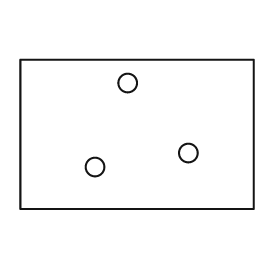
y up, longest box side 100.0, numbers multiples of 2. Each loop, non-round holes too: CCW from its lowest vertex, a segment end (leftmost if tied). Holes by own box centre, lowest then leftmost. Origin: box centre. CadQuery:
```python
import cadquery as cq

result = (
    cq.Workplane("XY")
    .moveTo(-50.0, -32.0)
    .lineTo(50.0, -32.0)
    .lineTo(50.0, 32.0)
    .lineTo(-50.0, 32.0)
    .close()
    .moveTo(-18.0, -14.0)
    .circle(4.0)
    .moveTo(22.0, -8.0)
    .circle(4.0)
    .moveTo(-4.0, 22.0)
    .circle(4.0)
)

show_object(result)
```